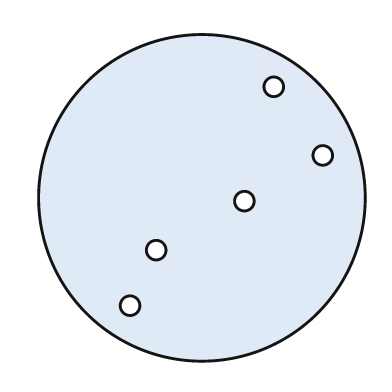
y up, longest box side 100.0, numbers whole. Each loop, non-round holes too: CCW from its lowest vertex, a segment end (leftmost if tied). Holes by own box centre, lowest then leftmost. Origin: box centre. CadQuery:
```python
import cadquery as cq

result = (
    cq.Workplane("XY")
    .moveTo(0.0, 0.0)
    .circle(50.0)
    .moveTo(-22.0, -33.0)
    .circle(3.0)
    .moveTo(-14.0, -16.0)
    .circle(3.0)
    .moveTo(13.0, -1.0)
    .circle(3.0)
    .moveTo(37.0, 13.0)
    .circle(3.0)
    .moveTo(22.0, 34.0)
    .circle(3.0)
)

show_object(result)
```